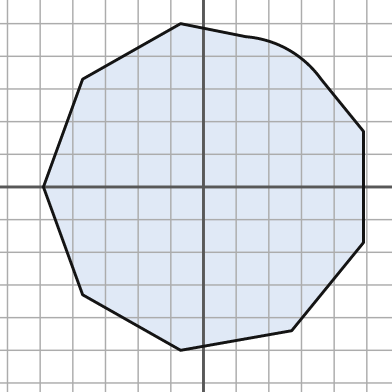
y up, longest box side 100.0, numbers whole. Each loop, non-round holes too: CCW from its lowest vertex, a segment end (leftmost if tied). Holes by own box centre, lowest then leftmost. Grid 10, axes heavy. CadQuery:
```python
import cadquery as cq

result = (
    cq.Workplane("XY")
    .moveTo(-7.0, -50.0)
    .lineTo(27.0, -44.0)
    .lineTo(49.0, -17.0)
    .lineTo(49.0, 17.0)
    .lineTo(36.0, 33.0)
    .threePointArc((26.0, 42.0), (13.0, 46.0))
    .lineTo(-7.0, 50.0)
    .lineTo(-37.0, 33.0)
    .lineTo(-49.0, 0.0)
    .lineTo(-37.0, -33.0)
    .close()
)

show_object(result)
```